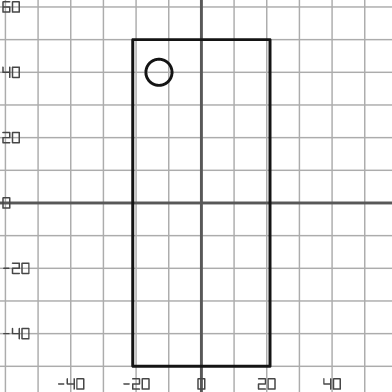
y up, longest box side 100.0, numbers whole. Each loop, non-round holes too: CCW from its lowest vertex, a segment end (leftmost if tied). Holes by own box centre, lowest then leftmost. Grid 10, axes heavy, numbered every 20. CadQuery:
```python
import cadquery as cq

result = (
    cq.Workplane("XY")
    .moveTo(-21.0, -50.0)
    .lineTo(21.0, -50.0)
    .lineTo(21.0, 50.0)
    .lineTo(-21.0, 50.0)
    .close()
    .moveTo(-13.0, 40.0)
    .circle(4.0)
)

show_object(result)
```